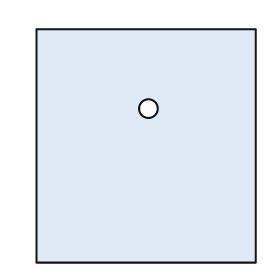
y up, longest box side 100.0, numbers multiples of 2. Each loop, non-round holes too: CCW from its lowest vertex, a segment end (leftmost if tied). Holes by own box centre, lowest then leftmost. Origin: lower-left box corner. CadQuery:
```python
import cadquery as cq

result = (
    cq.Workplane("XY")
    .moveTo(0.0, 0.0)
    .lineTo(94.0, 0.0)
    .lineTo(94.0, 100.0)
    .lineTo(0.0, 100.0)
    .close()
    .moveTo(48.0, 66.0)
    .circle(4.0)
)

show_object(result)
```